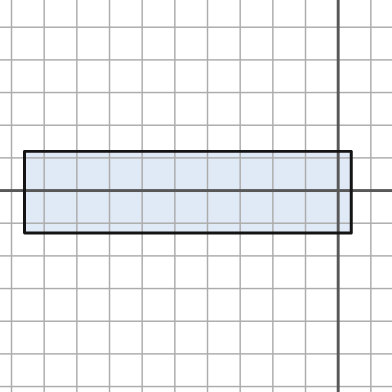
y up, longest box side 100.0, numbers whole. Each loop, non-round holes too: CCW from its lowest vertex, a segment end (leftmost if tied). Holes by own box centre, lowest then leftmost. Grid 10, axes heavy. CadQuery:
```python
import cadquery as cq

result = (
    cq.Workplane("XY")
    .moveTo(-96.0, -13.0)
    .lineTo(4.0, -13.0)
    .lineTo(4.0, 12.0)
    .lineTo(-96.0, 12.0)
    .close()
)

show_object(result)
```